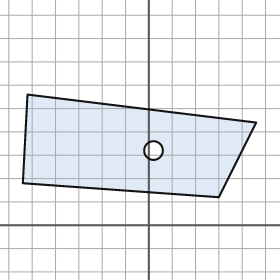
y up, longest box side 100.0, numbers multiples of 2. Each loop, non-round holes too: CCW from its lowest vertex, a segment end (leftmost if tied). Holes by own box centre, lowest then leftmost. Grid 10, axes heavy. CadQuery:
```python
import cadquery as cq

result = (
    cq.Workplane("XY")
    .moveTo(30.0, 12.0)
    .lineTo(46.0, 44.0)
    .lineTo(-52.0, 56.0)
    .lineTo(-54.0, 18.0)
    .close()
    .moveTo(2.0, 32.0)
    .circle(4.0)
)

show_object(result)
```